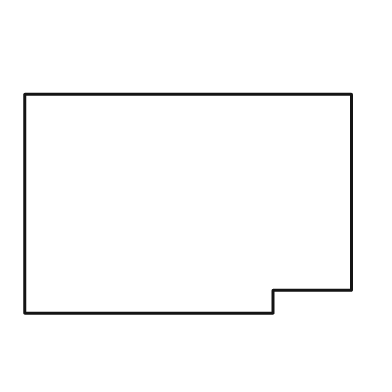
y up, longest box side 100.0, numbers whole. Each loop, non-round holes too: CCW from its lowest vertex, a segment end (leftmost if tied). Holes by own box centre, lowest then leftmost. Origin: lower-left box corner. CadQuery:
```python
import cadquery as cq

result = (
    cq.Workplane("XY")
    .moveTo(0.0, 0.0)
    .lineTo(76.0, 0.0)
    .lineTo(76.0, 7.0)
    .lineTo(100.0, 7.0)
    .lineTo(100.0, 67.0)
    .lineTo(0.0, 67.0)
    .close()
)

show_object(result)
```